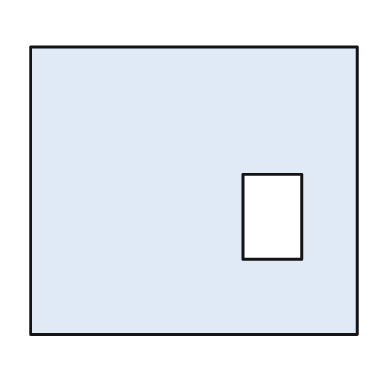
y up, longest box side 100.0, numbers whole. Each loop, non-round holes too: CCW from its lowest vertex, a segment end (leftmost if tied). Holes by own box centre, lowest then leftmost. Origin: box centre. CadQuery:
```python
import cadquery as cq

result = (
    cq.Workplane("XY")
    .moveTo(-50.0, -44.0)
    .lineTo(50.0, -44.0)
    .lineTo(50.0, 44.0)
    .lineTo(-50.0, 44.0)
    .close()
    .moveTo(15.0, -21.0)
    .lineTo(33.0, -21.0)
    .lineTo(33.0, 5.0)
    .lineTo(15.0, 5.0)
    .close()
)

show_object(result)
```